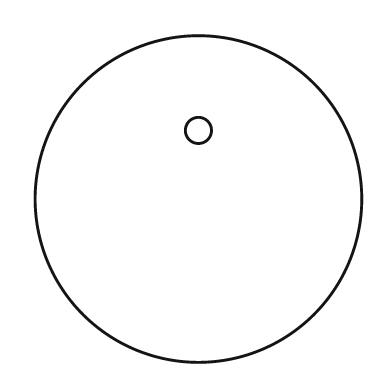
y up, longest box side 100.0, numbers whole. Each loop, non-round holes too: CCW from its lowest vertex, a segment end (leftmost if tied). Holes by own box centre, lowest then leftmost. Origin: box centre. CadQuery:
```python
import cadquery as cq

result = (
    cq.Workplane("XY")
    .moveTo(0.0, 0.0)
    .circle(50.0)
    .moveTo(0.0, 21.0)
    .circle(4.0)
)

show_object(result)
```